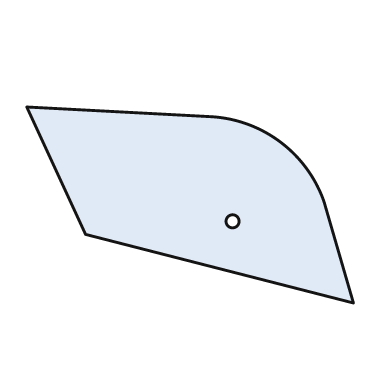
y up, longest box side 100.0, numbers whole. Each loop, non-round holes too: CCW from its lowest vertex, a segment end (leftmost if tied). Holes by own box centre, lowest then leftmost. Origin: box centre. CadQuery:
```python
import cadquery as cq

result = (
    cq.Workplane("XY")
    .moveTo(50.0, -30.0)
    .lineTo(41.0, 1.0)
    .threePointArc((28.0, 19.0), (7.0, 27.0))
    .lineTo(-50.0, 30.0)
    .lineTo(-32.0, -9.0)
    .close()
    .moveTo(13.0, -5.0)
    .circle(2.0)
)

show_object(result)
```